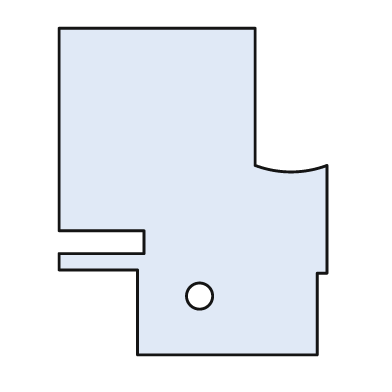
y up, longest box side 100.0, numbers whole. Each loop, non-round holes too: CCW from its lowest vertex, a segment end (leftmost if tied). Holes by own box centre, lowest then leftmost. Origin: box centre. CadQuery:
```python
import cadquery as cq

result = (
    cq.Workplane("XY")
    .moveTo(-17.0, -50.0)
    .lineTo(38.0, -50.0)
    .lineTo(38.0, -25.0)
    .lineTo(41.0, -25.0)
    .lineTo(41.0, 8.0)
    .threePointArc((30.0, 6.0), (19.0, 8.0))
    .lineTo(19.0, 50.0)
    .lineTo(-41.0, 50.0)
    .lineTo(-41.0, -12.0)
    .lineTo(-15.0, -12.0)
    .lineTo(-15.0, -19.0)
    .lineTo(-41.0, -19.0)
    .lineTo(-41.0, -24.0)
    .lineTo(-17.0, -24.0)
    .close()
    .moveTo(2.0, -32.0)
    .circle(4.0)
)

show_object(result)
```